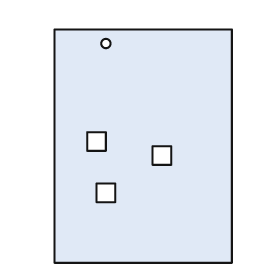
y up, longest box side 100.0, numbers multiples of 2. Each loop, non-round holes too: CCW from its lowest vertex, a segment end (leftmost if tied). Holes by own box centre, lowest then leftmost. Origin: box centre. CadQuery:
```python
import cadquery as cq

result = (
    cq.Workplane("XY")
    .moveTo(-38.0, -50.0)
    .lineTo(38.0, -50.0)
    .lineTo(38.0, 50.0)
    .lineTo(-38.0, 50.0)
    .close()
    .moveTo(-20.0, -24.0)
    .lineTo(-12.0, -24.0)
    .lineTo(-12.0, -16.0)
    .lineTo(-20.0, -16.0)
    .close()
    .moveTo(4.0, -8.0)
    .lineTo(12.0, -8.0)
    .lineTo(12.0, 0.0)
    .lineTo(4.0, 0.0)
    .close()
    .moveTo(-24.0, -2.0)
    .lineTo(-16.0, -2.0)
    .lineTo(-16.0, 6.0)
    .lineTo(-24.0, 6.0)
    .close()
    .moveTo(-16.0, 44.0)
    .circle(2.0)
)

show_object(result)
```